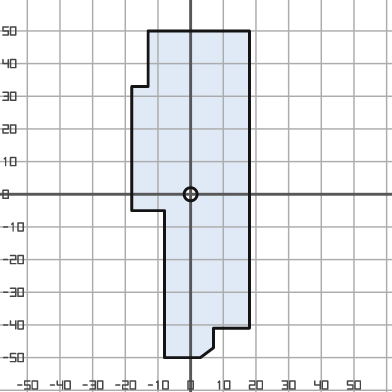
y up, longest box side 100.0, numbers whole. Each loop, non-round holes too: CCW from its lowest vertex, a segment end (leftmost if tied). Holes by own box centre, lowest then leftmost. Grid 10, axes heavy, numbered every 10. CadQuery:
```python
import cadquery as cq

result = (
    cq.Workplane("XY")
    .moveTo(-8.0, -50.0)
    .lineTo(3.0, -50.0)
    .lineTo(7.0, -47.0)
    .lineTo(7.0, -41.0)
    .lineTo(18.0, -41.0)
    .lineTo(18.0, 50.0)
    .lineTo(-13.0, 50.0)
    .lineTo(-13.0, 33.0)
    .lineTo(-18.0, 33.0)
    .lineTo(-18.0, -5.0)
    .lineTo(-8.0, -5.0)
    .close()
    .moveTo(0.0, 0.0)
    .circle(2.0)
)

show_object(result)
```